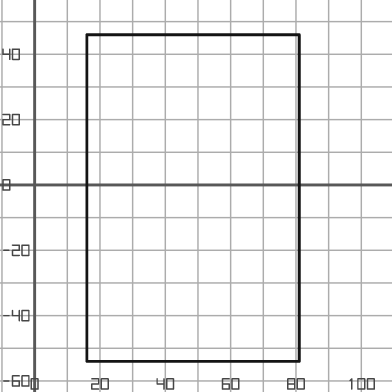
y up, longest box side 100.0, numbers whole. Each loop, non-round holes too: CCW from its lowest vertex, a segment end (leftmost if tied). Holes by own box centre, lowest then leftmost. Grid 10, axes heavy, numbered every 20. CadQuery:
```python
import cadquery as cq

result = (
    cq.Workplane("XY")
    .moveTo(16.0, -54.0)
    .lineTo(81.0, -54.0)
    .lineTo(81.0, 46.0)
    .lineTo(16.0, 46.0)
    .close()
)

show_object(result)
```